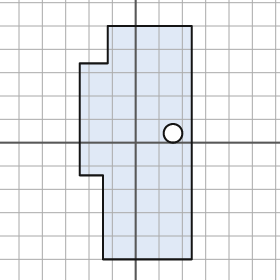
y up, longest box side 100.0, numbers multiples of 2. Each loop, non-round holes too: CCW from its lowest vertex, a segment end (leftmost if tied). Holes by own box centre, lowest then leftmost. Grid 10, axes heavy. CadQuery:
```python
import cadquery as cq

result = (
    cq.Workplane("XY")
    .moveTo(-14.0, -50.0)
    .lineTo(24.0, -50.0)
    .lineTo(24.0, 50.0)
    .lineTo(-12.0, 50.0)
    .lineTo(-12.0, 34.0)
    .lineTo(-24.0, 34.0)
    .lineTo(-24.0, -14.0)
    .lineTo(-14.0, -14.0)
    .close()
    .moveTo(16.0, 4.0)
    .circle(4.0)
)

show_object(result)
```